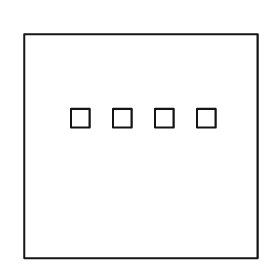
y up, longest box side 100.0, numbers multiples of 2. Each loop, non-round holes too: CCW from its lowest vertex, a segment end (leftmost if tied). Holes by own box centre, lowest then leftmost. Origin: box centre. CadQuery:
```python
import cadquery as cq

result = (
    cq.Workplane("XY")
    .moveTo(-50.0, -48.0)
    .lineTo(50.0, -48.0)
    .lineTo(50.0, 48.0)
    .lineTo(-50.0, 48.0)
    .close()
    .moveTo(-30.0, 8.0)
    .lineTo(-22.0, 8.0)
    .lineTo(-22.0, 16.0)
    .lineTo(-30.0, 16.0)
    .close()
    .moveTo(-12.0, 8.0)
    .lineTo(-4.0, 8.0)
    .lineTo(-4.0, 16.0)
    .lineTo(-12.0, 16.0)
    .close()
    .moveTo(6.0, 8.0)
    .lineTo(14.0, 8.0)
    .lineTo(14.0, 16.0)
    .lineTo(6.0, 16.0)
    .close()
    .moveTo(24.0, 8.0)
    .lineTo(32.0, 8.0)
    .lineTo(32.0, 16.0)
    .lineTo(24.0, 16.0)
    .close()
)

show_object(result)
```